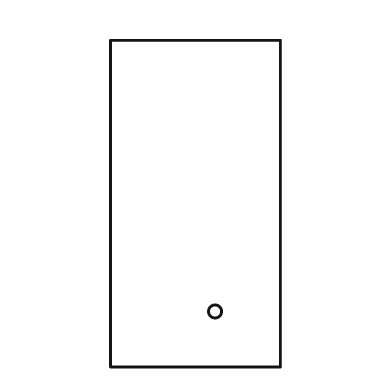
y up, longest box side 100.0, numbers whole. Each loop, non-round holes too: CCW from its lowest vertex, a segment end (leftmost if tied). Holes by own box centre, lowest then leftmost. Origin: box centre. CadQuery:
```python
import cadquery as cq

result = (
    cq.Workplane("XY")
    .moveTo(-26.0, -50.0)
    .lineTo(26.0, -50.0)
    .lineTo(26.0, 50.0)
    .lineTo(-26.0, 50.0)
    .close()
    .moveTo(6.0, -33.0)
    .circle(2.0)
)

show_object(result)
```